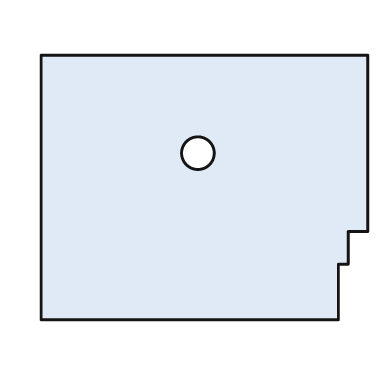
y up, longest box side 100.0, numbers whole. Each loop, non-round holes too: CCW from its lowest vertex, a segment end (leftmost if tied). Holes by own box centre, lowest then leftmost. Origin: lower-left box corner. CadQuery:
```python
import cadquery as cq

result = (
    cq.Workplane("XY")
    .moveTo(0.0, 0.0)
    .lineTo(91.0, 0.0)
    .lineTo(91.0, 17.0)
    .lineTo(94.0, 17.0)
    .lineTo(94.0, 27.0)
    .lineTo(100.0, 27.0)
    .lineTo(100.0, 81.0)
    .lineTo(0.0, 81.0)
    .close()
    .moveTo(48.0, 51.0)
    .circle(5.0)
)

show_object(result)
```